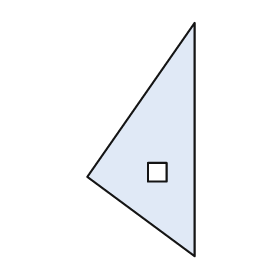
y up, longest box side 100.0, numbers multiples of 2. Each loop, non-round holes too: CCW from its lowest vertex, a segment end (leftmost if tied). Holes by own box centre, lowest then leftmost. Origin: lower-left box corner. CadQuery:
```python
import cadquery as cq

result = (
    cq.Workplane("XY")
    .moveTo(46.0, 0.0)
    .lineTo(46.0, 100.0)
    .lineTo(0.0, 34.0)
    .close()
    .moveTo(26.0, 32.0)
    .lineTo(34.0, 32.0)
    .lineTo(34.0, 40.0)
    .lineTo(26.0, 40.0)
    .close()
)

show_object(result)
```